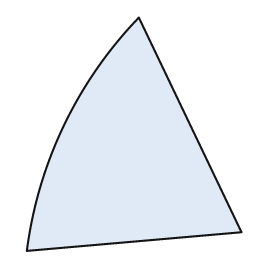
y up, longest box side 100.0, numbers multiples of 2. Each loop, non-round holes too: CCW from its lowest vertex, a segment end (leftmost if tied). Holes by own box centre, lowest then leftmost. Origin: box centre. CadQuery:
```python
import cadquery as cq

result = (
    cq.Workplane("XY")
    .moveTo(-46.0, -50.0)
    .lineTo(46.0, -42.0)
    .lineTo(2.0, 50.0)
    .threePointArc((-30.0, 4.0), (-46.0, -50.0))
    .close()
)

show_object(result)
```